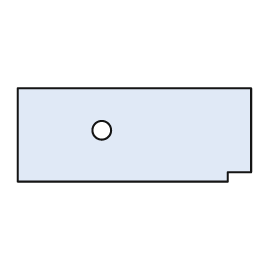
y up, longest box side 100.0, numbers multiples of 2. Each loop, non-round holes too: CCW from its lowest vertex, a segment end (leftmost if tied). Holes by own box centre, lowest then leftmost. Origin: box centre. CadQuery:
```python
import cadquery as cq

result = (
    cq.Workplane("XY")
    .moveTo(-50.0, -20.0)
    .lineTo(40.0, -20.0)
    .lineTo(40.0, -16.0)
    .lineTo(50.0, -16.0)
    .lineTo(50.0, 20.0)
    .lineTo(-50.0, 20.0)
    .close()
    .moveTo(-14.0, 2.0)
    .circle(4.0)
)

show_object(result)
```